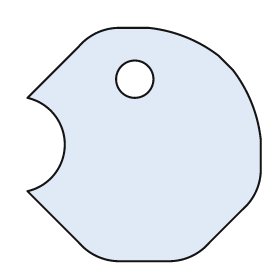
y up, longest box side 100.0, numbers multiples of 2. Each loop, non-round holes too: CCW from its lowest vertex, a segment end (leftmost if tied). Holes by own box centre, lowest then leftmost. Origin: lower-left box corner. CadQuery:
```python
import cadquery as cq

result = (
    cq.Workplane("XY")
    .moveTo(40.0, 0.0)
    .lineTo(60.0, 0.0)
    .threePointArc((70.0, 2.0), (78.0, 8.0))
    .lineTo(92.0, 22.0)
    .threePointArc((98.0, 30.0), (100.0, 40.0))
    .lineTo(100.0, 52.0)
    .threePointArc((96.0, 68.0), (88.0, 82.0))
    .lineTo(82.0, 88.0)
    .threePointArc((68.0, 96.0), (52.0, 100.0))
    .lineTo(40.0, 100.0)
    .threePointArc((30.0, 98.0), (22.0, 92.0))
    .lineTo(0.0, 70.0)
    .threePointArc((16.0, 50.0), (0.0, 30.0))
    .lineTo(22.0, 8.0)
    .threePointArc((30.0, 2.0), (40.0, 0.0))
    .close()
    .moveTo(46.0, 78.0)
    .circle(8.0)
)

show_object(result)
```